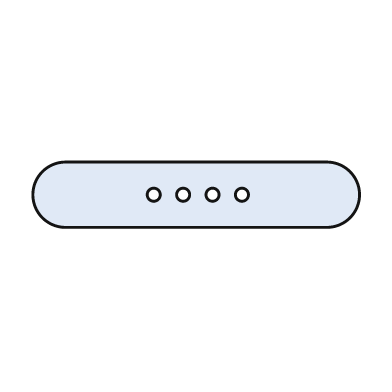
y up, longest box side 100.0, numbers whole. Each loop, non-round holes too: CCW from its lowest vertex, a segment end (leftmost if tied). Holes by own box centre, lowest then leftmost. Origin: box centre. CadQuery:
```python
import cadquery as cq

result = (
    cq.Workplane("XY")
    .moveTo(-40.0, -10.0)
    .lineTo(40.0, -10.0)
    .threePointArc((50.0, 0.0), (40.0, 10.0))
    .lineTo(-40.0, 10.0)
    .threePointArc((-50.0, 0.0), (-40.0, -10.0))
    .close()
    .moveTo(-13.0, 0.0)
    .circle(2.0)
    .moveTo(-4.0, 0.0)
    .circle(2.0)
    .moveTo(5.0, 0.0)
    .circle(2.0)
    .moveTo(14.0, 0.0)
    .circle(2.0)
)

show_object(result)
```